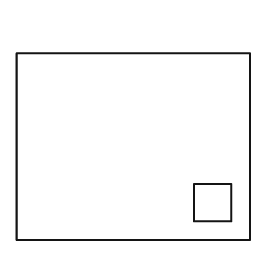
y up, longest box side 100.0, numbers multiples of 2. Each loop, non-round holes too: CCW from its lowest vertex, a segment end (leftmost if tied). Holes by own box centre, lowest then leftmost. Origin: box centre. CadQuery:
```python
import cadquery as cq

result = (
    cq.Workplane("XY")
    .moveTo(-50.0, -40.0)
    .lineTo(50.0, -40.0)
    .lineTo(50.0, 40.0)
    .lineTo(-50.0, 40.0)
    .close()
    .moveTo(26.0, -32.0)
    .lineTo(42.0, -32.0)
    .lineTo(42.0, -16.0)
    .lineTo(26.0, -16.0)
    .close()
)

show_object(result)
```